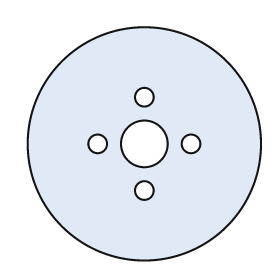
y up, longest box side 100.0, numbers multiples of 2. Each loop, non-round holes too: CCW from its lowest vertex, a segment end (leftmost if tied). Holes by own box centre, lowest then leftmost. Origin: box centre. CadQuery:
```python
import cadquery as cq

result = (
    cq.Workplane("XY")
    .moveTo(0.0, 0.0)
    .circle(50.0)
    .moveTo(0.0, -20.0)
    .circle(4.0)
    .moveTo(-20.0, 0.0)
    .circle(4.0)
    .moveTo(0.0, 0.0)
    .circle(10.0)
    .moveTo(20.0, 0.0)
    .circle(4.0)
    .moveTo(0.0, 20.0)
    .circle(4.0)
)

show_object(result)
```